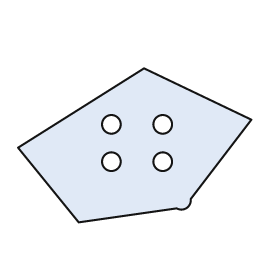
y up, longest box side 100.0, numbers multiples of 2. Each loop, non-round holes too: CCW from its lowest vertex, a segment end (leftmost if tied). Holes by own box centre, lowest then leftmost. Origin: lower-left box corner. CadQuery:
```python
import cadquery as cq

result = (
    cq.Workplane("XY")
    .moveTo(26.0, 0.0)
    .lineTo(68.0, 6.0)
    .threePointArc((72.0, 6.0), (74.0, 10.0))
    .lineTo(100.0, 44.0)
    .lineTo(54.0, 66.0)
    .lineTo(0.0, 32.0)
    .close()
    .moveTo(40.0, 26.0)
    .circle(4.0)
    .moveTo(62.0, 26.0)
    .circle(4.0)
    .moveTo(40.0, 42.0)
    .circle(4.0)
    .moveTo(62.0, 42.0)
    .circle(4.0)
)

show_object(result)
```